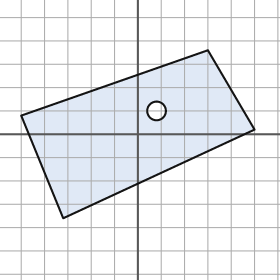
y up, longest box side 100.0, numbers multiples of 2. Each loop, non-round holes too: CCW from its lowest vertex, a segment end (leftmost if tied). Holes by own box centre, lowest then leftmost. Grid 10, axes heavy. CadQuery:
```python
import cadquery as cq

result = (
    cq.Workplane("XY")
    .moveTo(-32.0, -36.0)
    .lineTo(50.0, 2.0)
    .lineTo(30.0, 36.0)
    .lineTo(-50.0, 8.0)
    .close()
    .moveTo(8.0, 10.0)
    .circle(4.0)
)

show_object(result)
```